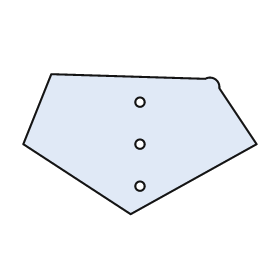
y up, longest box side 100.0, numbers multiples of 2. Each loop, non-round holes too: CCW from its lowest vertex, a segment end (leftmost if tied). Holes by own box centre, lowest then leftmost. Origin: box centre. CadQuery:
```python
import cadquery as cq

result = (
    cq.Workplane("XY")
    .moveTo(-4.0, -30.0)
    .lineTo(50.0, 0.0)
    .lineTo(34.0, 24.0)
    .threePointArc((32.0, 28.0), (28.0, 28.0))
    .lineTo(-38.0, 30.0)
    .lineTo(-50.0, 0.0)
    .close()
    .moveTo(0.0, -18.0)
    .circle(2.0)
    .moveTo(0.0, 0.0)
    .circle(2.0)
    .moveTo(0.0, 18.0)
    .circle(2.0)
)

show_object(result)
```